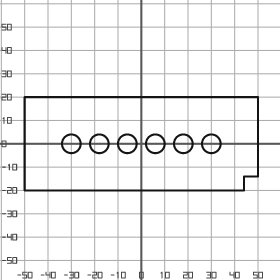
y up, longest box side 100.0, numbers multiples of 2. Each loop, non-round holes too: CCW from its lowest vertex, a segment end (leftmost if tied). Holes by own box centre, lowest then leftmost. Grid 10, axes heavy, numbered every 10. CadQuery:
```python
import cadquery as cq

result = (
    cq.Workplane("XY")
    .moveTo(-50.0, -20.0)
    .lineTo(44.0, -20.0)
    .lineTo(44.0, -14.0)
    .lineTo(50.0, -14.0)
    .lineTo(50.0, 20.0)
    .lineTo(-50.0, 20.0)
    .close()
    .moveTo(-30.0, 0.0)
    .circle(4.0)
    .moveTo(-18.0, 0.0)
    .circle(4.0)
    .moveTo(-6.0, 0.0)
    .circle(4.0)
    .moveTo(6.0, 0.0)
    .circle(4.0)
    .moveTo(18.0, 0.0)
    .circle(4.0)
    .moveTo(30.0, 0.0)
    .circle(4.0)
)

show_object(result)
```